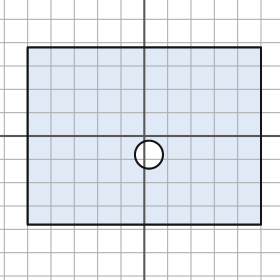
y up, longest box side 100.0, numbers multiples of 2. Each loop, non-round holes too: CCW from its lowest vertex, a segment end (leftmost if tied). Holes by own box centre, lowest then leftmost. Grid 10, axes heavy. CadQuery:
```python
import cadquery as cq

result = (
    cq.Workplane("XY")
    .moveTo(-50.0, -38.0)
    .lineTo(50.0, -38.0)
    .lineTo(50.0, 38.0)
    .lineTo(-50.0, 38.0)
    .close()
    .moveTo(2.0, -8.0)
    .circle(6.0)
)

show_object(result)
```